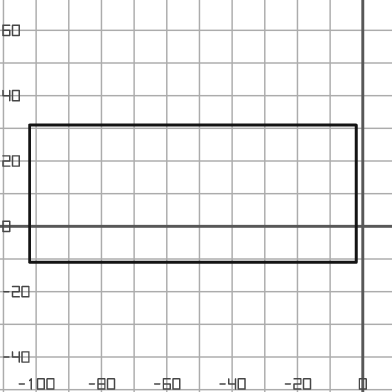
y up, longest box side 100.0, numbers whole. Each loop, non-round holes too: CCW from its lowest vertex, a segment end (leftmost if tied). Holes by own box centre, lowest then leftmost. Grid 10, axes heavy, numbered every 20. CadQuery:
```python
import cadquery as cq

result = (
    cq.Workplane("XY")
    .moveTo(-102.0, -11.0)
    .lineTo(-2.0, -11.0)
    .lineTo(-2.0, 31.0)
    .lineTo(-102.0, 31.0)
    .close()
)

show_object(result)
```